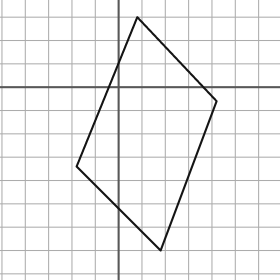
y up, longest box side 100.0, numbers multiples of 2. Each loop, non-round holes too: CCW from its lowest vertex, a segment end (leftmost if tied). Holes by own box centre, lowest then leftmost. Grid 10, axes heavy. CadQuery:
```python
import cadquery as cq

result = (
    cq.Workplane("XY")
    .moveTo(18.0, -70.0)
    .lineTo(42.0, -6.0)
    .lineTo(8.0, 30.0)
    .lineTo(-18.0, -34.0)
    .close()
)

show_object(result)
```